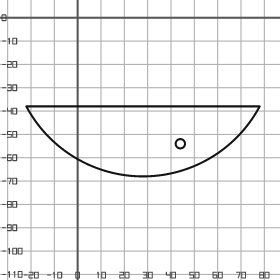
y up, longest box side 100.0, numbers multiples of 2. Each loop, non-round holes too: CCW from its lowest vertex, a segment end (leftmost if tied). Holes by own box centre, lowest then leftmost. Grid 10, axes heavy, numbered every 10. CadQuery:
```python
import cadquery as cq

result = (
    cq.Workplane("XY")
    .moveTo(-22.0, -38.0)
    .threePointArc((28.0, -68.0), (78.0, -38.0))
    .close()
    .moveTo(44.0, -54.0)
    .circle(2.0)
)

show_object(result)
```